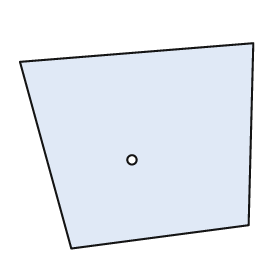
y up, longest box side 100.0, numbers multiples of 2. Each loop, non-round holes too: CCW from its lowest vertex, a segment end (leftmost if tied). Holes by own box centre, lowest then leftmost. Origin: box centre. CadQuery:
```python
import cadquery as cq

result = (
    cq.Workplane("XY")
    .moveTo(-28.0, -44.0)
    .lineTo(48.0, -34.0)
    .lineTo(50.0, 44.0)
    .lineTo(-50.0, 36.0)
    .close()
    .moveTo(-2.0, -6.0)
    .circle(2.0)
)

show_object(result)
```